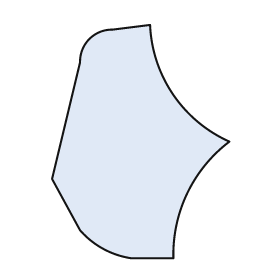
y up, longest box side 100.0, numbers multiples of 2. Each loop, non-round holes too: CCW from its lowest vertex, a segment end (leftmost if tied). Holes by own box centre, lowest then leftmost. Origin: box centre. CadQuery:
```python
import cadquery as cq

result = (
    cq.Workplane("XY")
    .moveTo(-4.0, -50.0)
    .lineTo(14.0, -50.0)
    .threePointArc((20.0, -22.0), (38.0, 0.0))
    .threePointArc((14.0, 20.0), (4.0, 50.0))
    .lineTo(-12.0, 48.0)
    .threePointArc((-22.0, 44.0), (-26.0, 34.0))
    .lineTo(-38.0, -16.0)
    .lineTo(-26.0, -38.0)
    .threePointArc((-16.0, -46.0), (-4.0, -50.0))
    .close()
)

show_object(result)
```